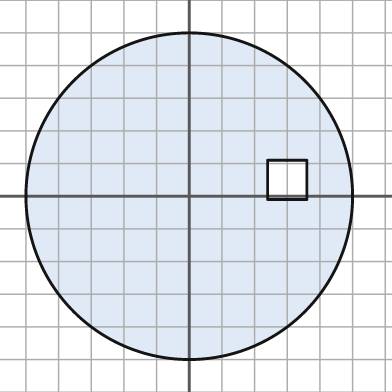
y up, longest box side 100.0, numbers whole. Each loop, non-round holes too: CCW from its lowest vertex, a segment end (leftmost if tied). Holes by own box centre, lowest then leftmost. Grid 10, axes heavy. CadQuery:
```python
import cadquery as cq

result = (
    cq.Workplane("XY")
    .moveTo(0.0, 0.0)
    .circle(50.0)
    .moveTo(24.0, -1.0)
    .lineTo(36.0, -1.0)
    .lineTo(36.0, 11.0)
    .lineTo(24.0, 11.0)
    .close()
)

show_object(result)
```